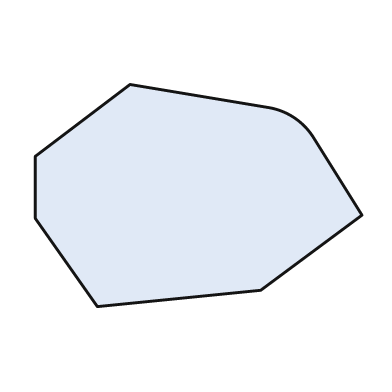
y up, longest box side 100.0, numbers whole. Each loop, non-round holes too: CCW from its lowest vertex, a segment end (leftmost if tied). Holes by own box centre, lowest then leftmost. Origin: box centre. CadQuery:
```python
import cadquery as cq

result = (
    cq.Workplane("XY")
    .moveTo(-31.0, -34.0)
    .lineTo(19.0, -29.0)
    .lineTo(50.0, -6.0)
    .lineTo(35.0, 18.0)
    .threePointArc((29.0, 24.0), (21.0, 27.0))
    .lineTo(-21.0, 34.0)
    .lineTo(-50.0, 12.0)
    .lineTo(-50.0, -7.0)
    .close()
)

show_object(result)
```